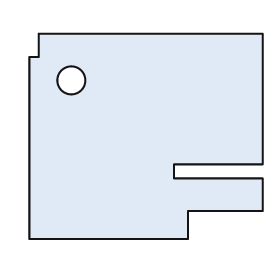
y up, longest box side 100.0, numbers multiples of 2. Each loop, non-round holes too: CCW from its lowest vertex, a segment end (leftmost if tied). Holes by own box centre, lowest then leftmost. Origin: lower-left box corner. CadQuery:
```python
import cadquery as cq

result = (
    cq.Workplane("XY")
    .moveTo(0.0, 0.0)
    .lineTo(68.0, 0.0)
    .lineTo(68.0, 12.0)
    .lineTo(100.0, 12.0)
    .lineTo(100.0, 26.0)
    .lineTo(62.0, 26.0)
    .lineTo(62.0, 32.0)
    .lineTo(100.0, 32.0)
    .lineTo(100.0, 88.0)
    .lineTo(4.0, 88.0)
    .lineTo(4.0, 78.0)
    .lineTo(0.0, 78.0)
    .close()
    .moveTo(18.0, 68.0)
    .circle(6.0)
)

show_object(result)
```